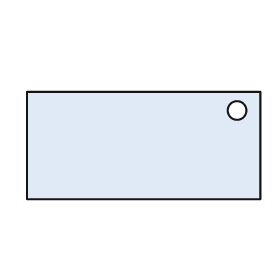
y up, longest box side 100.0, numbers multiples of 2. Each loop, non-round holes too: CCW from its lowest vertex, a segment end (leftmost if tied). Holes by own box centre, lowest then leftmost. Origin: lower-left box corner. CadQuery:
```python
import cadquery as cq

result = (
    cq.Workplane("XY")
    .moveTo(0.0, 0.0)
    .lineTo(100.0, 0.0)
    .lineTo(100.0, 46.0)
    .lineTo(0.0, 46.0)
    .close()
    .moveTo(90.0, 38.0)
    .circle(4.0)
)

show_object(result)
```